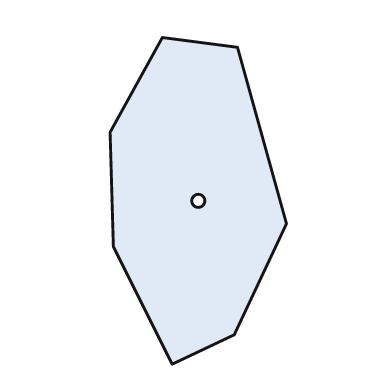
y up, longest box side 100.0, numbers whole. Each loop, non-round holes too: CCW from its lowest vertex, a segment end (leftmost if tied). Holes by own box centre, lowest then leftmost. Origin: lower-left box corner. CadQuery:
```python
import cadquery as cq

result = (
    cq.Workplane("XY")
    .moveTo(19.0, 0.0)
    .lineTo(38.0, 9.0)
    .lineTo(54.0, 43.0)
    .lineTo(39.0, 97.0)
    .lineTo(16.0, 100.0)
    .lineTo(0.0, 71.0)
    .lineTo(1.0, 36.0)
    .close()
    .moveTo(27.0, 50.0)
    .circle(2.0)
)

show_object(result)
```